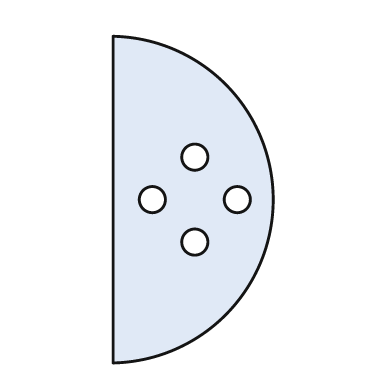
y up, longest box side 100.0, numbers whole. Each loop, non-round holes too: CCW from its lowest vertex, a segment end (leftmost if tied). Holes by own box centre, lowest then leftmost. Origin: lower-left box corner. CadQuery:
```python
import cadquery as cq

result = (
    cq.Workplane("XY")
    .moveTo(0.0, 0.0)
    .threePointArc((49.0, 50.0), (0.0, 100.0))
    .close()
    .moveTo(25.0, 37.0)
    .circle(4.0)
    .moveTo(12.0, 50.0)
    .circle(4.0)
    .moveTo(38.0, 50.0)
    .circle(4.0)
    .moveTo(25.0, 63.0)
    .circle(4.0)
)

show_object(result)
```